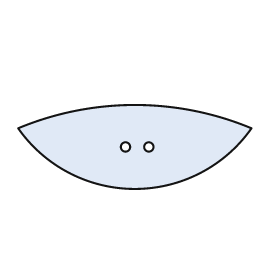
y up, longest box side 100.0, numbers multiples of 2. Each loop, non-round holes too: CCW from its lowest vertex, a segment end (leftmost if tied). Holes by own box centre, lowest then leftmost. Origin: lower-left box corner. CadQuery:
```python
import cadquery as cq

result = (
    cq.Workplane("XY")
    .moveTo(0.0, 26.0)
    .threePointArc((50.0, 0.0), (100.0, 26.0))
    .threePointArc((50.0, 36.0), (0.0, 26.0))
    .close()
    .moveTo(46.0, 18.0)
    .circle(2.0)
    .moveTo(56.0, 18.0)
    .circle(2.0)
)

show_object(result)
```